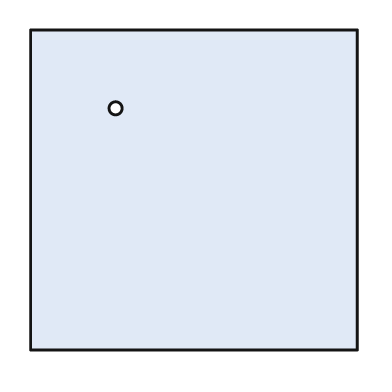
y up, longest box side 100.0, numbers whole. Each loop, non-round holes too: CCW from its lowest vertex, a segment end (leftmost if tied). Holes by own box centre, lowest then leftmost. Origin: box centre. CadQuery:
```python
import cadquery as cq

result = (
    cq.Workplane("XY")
    .moveTo(-50.0, -49.0)
    .lineTo(50.0, -49.0)
    .lineTo(50.0, 49.0)
    .lineTo(-50.0, 49.0)
    .close()
    .moveTo(-24.0, 25.0)
    .circle(2.0)
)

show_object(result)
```